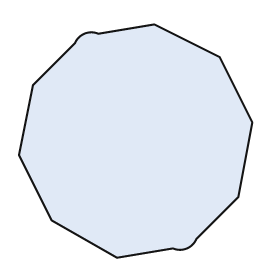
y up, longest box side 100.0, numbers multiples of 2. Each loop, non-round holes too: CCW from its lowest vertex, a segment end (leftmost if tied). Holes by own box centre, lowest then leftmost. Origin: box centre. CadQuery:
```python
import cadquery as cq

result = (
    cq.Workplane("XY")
    .moveTo(-8.0, -50.0)
    .lineTo(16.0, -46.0)
    .threePointArc((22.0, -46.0), (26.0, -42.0))
    .lineTo(44.0, -24.0)
    .lineTo(50.0, 8.0)
    .lineTo(36.0, 36.0)
    .lineTo(8.0, 50.0)
    .lineTo(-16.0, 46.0)
    .threePointArc((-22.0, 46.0), (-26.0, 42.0))
    .lineTo(-44.0, 24.0)
    .lineTo(-50.0, -6.0)
    .lineTo(-36.0, -34.0)
    .close()
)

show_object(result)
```